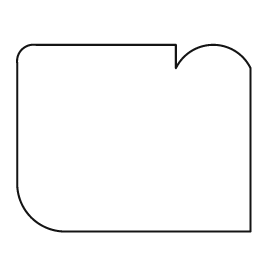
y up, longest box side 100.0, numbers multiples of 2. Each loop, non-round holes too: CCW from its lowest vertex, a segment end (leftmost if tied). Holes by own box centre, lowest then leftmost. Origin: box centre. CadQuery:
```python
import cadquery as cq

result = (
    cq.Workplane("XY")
    .moveTo(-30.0, -40.0)
    .lineTo(50.0, -40.0)
    .lineTo(50.0, 30.0)
    .threePointArc((34.0, 40.0), (18.0, 30.0))
    .lineTo(18.0, 40.0)
    .lineTo(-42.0, 40.0)
    .threePointArc((-48.0, 38.0), (-50.0, 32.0))
    .lineTo(-50.0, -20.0)
    .threePointArc((-44.0, -34.0), (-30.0, -40.0))
    .close()
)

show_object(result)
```